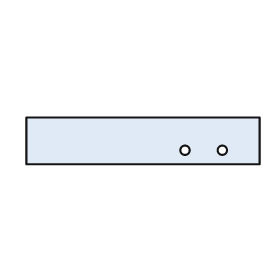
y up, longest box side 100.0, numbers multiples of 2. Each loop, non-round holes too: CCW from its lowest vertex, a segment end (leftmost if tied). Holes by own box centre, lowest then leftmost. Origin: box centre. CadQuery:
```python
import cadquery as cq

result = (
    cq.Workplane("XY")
    .moveTo(-50.0, -10.0)
    .lineTo(50.0, -10.0)
    .lineTo(50.0, 10.0)
    .lineTo(-50.0, 10.0)
    .close()
    .moveTo(18.0, -4.0)
    .circle(2.0)
    .moveTo(34.0, -4.0)
    .circle(2.0)
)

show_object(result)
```